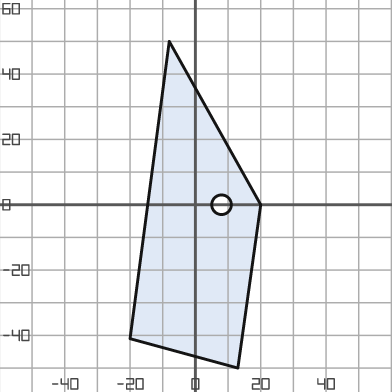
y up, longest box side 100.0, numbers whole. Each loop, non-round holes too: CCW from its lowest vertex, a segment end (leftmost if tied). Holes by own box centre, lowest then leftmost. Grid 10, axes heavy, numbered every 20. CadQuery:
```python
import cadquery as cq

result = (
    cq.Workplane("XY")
    .moveTo(13.0, -50.0)
    .lineTo(20.0, 0.0)
    .lineTo(-8.0, 50.0)
    .lineTo(-20.0, -41.0)
    .close()
    .moveTo(8.0, 0.0)
    .circle(3.0)
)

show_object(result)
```